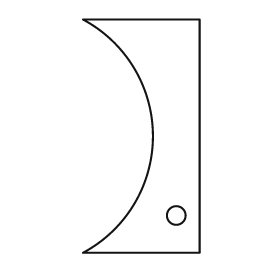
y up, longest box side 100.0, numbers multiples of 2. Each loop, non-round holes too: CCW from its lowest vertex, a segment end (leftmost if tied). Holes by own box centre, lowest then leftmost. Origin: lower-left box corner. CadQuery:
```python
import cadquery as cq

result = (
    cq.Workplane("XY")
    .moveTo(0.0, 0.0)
    .lineTo(50.0, 0.0)
    .lineTo(50.0, 100.0)
    .lineTo(0.0, 100.0)
    .threePointArc((30.0, 50.0), (0.0, 0.0))
    .close()
    .moveTo(40.0, 16.0)
    .circle(4.0)
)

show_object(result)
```